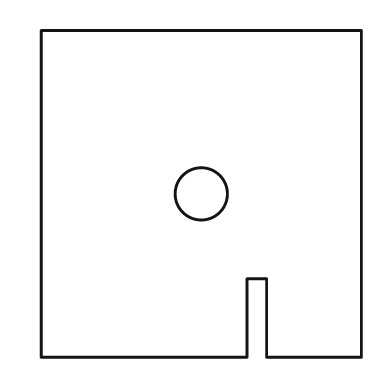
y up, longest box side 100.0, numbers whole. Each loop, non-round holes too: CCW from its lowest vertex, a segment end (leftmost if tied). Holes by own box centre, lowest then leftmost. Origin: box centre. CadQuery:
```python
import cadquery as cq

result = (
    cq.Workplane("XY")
    .moveTo(-49.0, -50.0)
    .lineTo(14.0, -50.0)
    .lineTo(14.0, -26.0)
    .lineTo(20.0, -26.0)
    .lineTo(20.0, -50.0)
    .lineTo(49.0, -50.0)
    .lineTo(49.0, 50.0)
    .lineTo(-49.0, 50.0)
    .close()
    .moveTo(0.0, 0.0)
    .circle(8.0)
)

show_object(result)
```